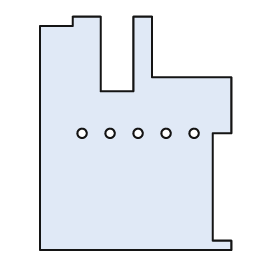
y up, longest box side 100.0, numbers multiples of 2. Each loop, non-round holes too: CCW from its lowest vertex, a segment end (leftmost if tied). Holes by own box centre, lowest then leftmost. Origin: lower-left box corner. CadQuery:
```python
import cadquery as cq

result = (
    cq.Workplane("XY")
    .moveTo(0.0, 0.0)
    .lineTo(82.0, 0.0)
    .lineTo(82.0, 4.0)
    .lineTo(74.0, 4.0)
    .lineTo(74.0, 50.0)
    .lineTo(82.0, 50.0)
    .lineTo(82.0, 74.0)
    .lineTo(48.0, 74.0)
    .lineTo(48.0, 100.0)
    .lineTo(40.0, 100.0)
    .lineTo(40.0, 68.0)
    .lineTo(26.0, 68.0)
    .lineTo(26.0, 100.0)
    .lineTo(14.0, 100.0)
    .lineTo(14.0, 96.0)
    .lineTo(0.0, 96.0)
    .close()
    .moveTo(18.0, 50.0)
    .circle(2.0)
    .moveTo(30.0, 50.0)
    .circle(2.0)
    .moveTo(42.0, 50.0)
    .circle(2.0)
    .moveTo(54.0, 50.0)
    .circle(2.0)
    .moveTo(66.0, 50.0)
    .circle(2.0)
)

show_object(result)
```